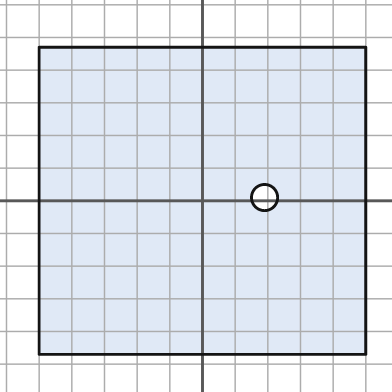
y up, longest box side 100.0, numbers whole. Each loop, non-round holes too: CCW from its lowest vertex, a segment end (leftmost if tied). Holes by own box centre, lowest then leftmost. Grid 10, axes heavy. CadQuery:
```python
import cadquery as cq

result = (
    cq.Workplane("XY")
    .moveTo(-50.0, -47.0)
    .lineTo(50.0, -47.0)
    .lineTo(50.0, 47.0)
    .lineTo(-50.0, 47.0)
    .close()
    .moveTo(19.0, 1.0)
    .circle(4.0)
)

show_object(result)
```